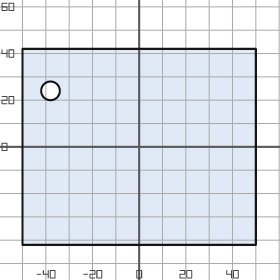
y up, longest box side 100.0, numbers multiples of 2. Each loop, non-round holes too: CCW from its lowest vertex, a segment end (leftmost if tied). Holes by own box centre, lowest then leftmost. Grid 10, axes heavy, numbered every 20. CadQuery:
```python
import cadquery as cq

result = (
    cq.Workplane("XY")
    .moveTo(-50.0, -42.0)
    .lineTo(50.0, -42.0)
    .lineTo(50.0, 42.0)
    .lineTo(-50.0, 42.0)
    .close()
    .moveTo(-38.0, 24.0)
    .circle(4.0)
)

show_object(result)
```